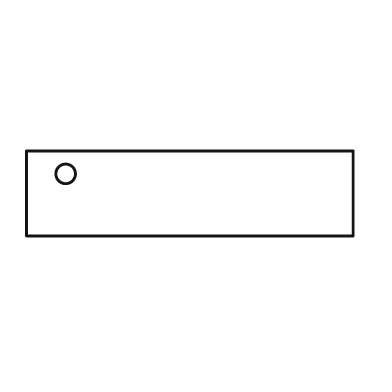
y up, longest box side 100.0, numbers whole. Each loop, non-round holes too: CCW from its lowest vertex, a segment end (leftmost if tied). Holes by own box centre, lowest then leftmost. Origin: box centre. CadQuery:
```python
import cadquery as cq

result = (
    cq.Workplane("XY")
    .moveTo(-50.0, -13.0)
    .lineTo(50.0, -13.0)
    .lineTo(50.0, 13.0)
    .lineTo(-50.0, 13.0)
    .close()
    .moveTo(-38.0, 6.0)
    .circle(3.0)
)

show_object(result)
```